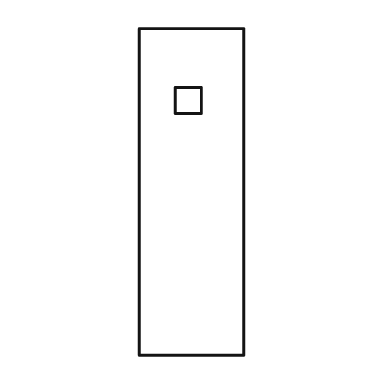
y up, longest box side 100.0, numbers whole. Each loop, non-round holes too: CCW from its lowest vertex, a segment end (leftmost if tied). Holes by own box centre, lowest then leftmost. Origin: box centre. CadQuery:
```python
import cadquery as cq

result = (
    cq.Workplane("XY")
    .moveTo(-16.0, -50.0)
    .lineTo(16.0, -50.0)
    .lineTo(16.0, 50.0)
    .lineTo(-16.0, 50.0)
    .close()
    .moveTo(-5.0, 24.0)
    .lineTo(3.0, 24.0)
    .lineTo(3.0, 32.0)
    .lineTo(-5.0, 32.0)
    .close()
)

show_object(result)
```